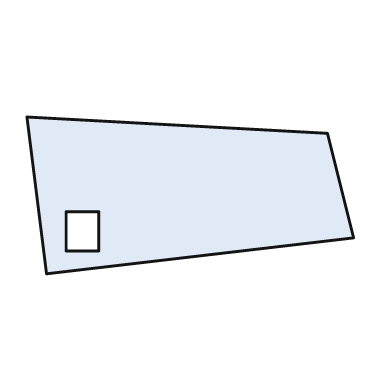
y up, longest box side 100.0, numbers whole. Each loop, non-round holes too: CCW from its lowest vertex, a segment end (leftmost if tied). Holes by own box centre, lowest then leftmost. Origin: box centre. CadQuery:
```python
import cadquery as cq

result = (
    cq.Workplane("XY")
    .moveTo(-44.0, -24.0)
    .lineTo(50.0, -13.0)
    .lineTo(42.0, 19.0)
    .lineTo(-50.0, 24.0)
    .close()
    .moveTo(-38.0, -17.0)
    .lineTo(-28.0, -17.0)
    .lineTo(-28.0, -5.0)
    .lineTo(-38.0, -5.0)
    .close()
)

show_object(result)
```